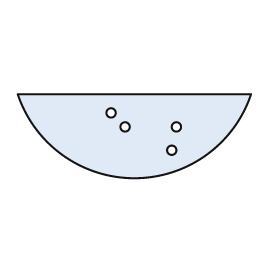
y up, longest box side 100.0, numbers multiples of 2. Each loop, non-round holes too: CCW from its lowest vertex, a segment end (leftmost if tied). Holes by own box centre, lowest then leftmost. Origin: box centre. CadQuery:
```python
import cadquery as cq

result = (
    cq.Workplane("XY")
    .moveTo(-50.0, 18.0)
    .threePointArc((0.0, -18.0), (50.0, 18.0))
    .close()
    .moveTo(16.0, -6.0)
    .circle(2.0)
    .moveTo(-4.0, 4.0)
    .circle(2.0)
    .moveTo(18.0, 4.0)
    .circle(2.0)
    .moveTo(-10.0, 10.0)
    .circle(2.0)
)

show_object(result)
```